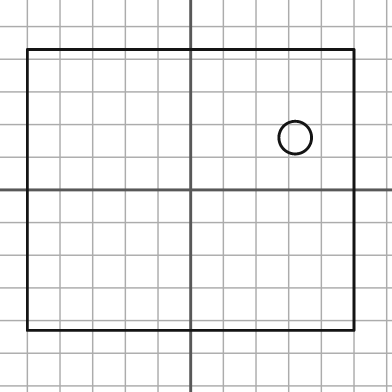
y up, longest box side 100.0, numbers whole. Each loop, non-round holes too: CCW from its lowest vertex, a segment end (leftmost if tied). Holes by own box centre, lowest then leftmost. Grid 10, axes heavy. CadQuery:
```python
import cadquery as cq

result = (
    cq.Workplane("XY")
    .moveTo(-50.0, -43.0)
    .lineTo(50.0, -43.0)
    .lineTo(50.0, 43.0)
    .lineTo(-50.0, 43.0)
    .close()
    .moveTo(32.0, 16.0)
    .circle(5.0)
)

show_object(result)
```